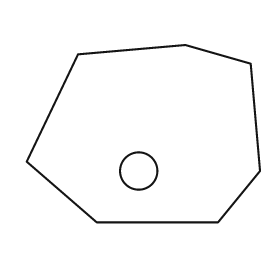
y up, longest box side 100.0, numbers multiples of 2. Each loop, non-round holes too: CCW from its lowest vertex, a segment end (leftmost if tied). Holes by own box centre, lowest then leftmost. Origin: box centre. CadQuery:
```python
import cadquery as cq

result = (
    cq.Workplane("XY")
    .moveTo(-20.0, -38.0)
    .lineTo(32.0, -38.0)
    .lineTo(50.0, -16.0)
    .lineTo(46.0, 30.0)
    .lineTo(18.0, 38.0)
    .lineTo(-28.0, 34.0)
    .lineTo(-50.0, -12.0)
    .close()
    .moveTo(-2.0, -16.0)
    .circle(8.0)
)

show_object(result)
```